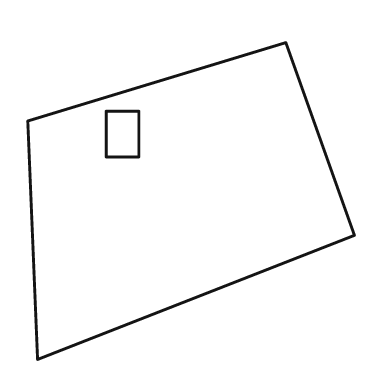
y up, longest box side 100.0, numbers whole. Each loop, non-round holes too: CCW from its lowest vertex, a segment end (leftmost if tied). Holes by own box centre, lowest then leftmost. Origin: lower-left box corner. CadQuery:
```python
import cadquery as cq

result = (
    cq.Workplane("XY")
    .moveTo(3.0, 0.0)
    .lineTo(100.0, 38.0)
    .lineTo(79.0, 97.0)
    .lineTo(0.0, 73.0)
    .close()
    .moveTo(24.0, 62.0)
    .lineTo(34.0, 62.0)
    .lineTo(34.0, 76.0)
    .lineTo(24.0, 76.0)
    .close()
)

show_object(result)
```